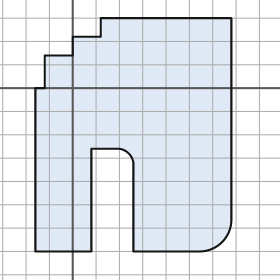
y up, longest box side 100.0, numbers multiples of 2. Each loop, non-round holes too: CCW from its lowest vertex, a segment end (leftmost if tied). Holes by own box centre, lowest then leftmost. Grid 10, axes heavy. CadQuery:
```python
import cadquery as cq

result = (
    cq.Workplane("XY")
    .moveTo(-16.0, -70.0)
    .lineTo(8.0, -70.0)
    .lineTo(8.0, -26.0)
    .lineTo(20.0, -26.0)
    .threePointArc((24.0, -28.0), (26.0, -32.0))
    .lineTo(26.0, -70.0)
    .lineTo(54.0, -70.0)
    .threePointArc((64.0, -66.0), (68.0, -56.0))
    .lineTo(68.0, 30.0)
    .lineTo(12.0, 30.0)
    .lineTo(12.0, 22.0)
    .lineTo(0.0, 22.0)
    .lineTo(0.0, 14.0)
    .lineTo(-12.0, 14.0)
    .lineTo(-12.0, 0.0)
    .lineTo(-16.0, 0.0)
    .close()
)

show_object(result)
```